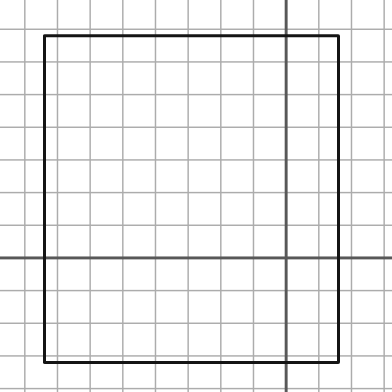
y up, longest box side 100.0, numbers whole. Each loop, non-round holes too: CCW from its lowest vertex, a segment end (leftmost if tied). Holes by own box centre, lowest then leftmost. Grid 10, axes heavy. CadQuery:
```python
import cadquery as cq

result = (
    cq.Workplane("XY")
    .moveTo(-74.0, -32.0)
    .lineTo(16.0, -32.0)
    .lineTo(16.0, 68.0)
    .lineTo(-74.0, 68.0)
    .close()
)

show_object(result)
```